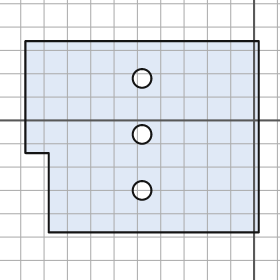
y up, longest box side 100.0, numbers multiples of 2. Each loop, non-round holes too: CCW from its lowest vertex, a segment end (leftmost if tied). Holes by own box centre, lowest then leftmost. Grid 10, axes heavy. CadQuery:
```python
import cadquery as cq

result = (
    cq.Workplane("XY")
    .moveTo(-88.0, -48.0)
    .lineTo(2.0, -48.0)
    .lineTo(2.0, 34.0)
    .lineTo(-98.0, 34.0)
    .lineTo(-98.0, -14.0)
    .lineTo(-88.0, -14.0)
    .close()
    .moveTo(-48.0, -30.0)
    .circle(4.0)
    .moveTo(-48.0, -6.0)
    .circle(4.0)
    .moveTo(-48.0, 18.0)
    .circle(4.0)
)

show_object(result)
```